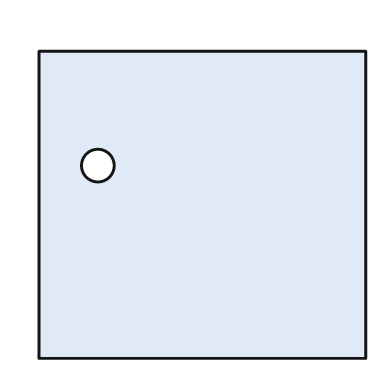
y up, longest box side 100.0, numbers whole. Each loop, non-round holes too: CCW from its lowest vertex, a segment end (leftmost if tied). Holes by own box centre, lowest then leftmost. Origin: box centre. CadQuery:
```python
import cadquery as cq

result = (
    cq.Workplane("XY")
    .moveTo(-50.0, -47.0)
    .lineTo(50.0, -47.0)
    .lineTo(50.0, 47.0)
    .lineTo(-50.0, 47.0)
    .close()
    .moveTo(-32.0, 12.0)
    .circle(5.0)
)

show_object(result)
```